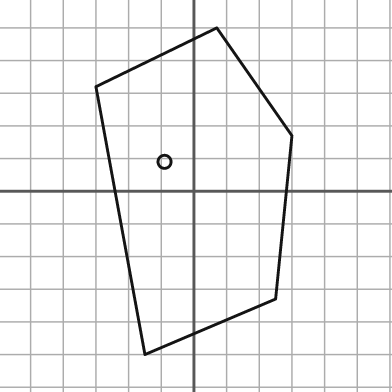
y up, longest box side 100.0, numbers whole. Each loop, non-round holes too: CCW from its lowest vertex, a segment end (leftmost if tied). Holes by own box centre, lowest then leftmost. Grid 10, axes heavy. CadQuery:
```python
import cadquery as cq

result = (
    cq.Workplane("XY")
    .moveTo(-15.0, -50.0)
    .lineTo(25.0, -33.0)
    .lineTo(30.0, 17.0)
    .lineTo(7.0, 50.0)
    .lineTo(-30.0, 32.0)
    .close()
    .moveTo(-9.0, 9.0)
    .circle(2.0)
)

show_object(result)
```